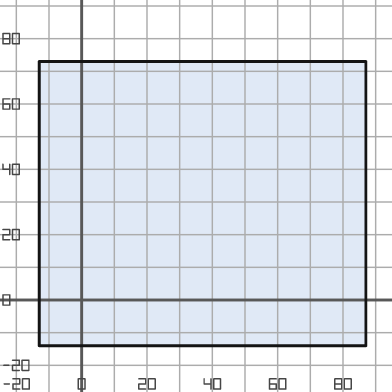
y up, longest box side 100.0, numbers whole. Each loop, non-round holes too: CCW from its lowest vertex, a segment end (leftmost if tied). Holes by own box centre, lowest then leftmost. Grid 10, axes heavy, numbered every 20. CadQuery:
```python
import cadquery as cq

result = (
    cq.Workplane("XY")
    .moveTo(-13.0, -14.0)
    .lineTo(87.0, -14.0)
    .lineTo(87.0, 73.0)
    .lineTo(-13.0, 73.0)
    .close()
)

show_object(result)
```